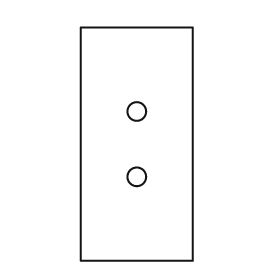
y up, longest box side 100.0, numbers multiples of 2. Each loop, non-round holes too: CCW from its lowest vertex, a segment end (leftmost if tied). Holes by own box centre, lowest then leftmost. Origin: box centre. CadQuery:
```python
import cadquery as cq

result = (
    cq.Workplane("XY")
    .moveTo(-24.0, -50.0)
    .lineTo(24.0, -50.0)
    .lineTo(24.0, 50.0)
    .lineTo(-24.0, 50.0)
    .close()
    .moveTo(0.0, -14.0)
    .circle(4.0)
    .moveTo(0.0, 14.0)
    .circle(4.0)
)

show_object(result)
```